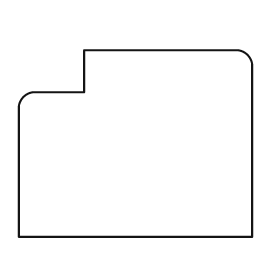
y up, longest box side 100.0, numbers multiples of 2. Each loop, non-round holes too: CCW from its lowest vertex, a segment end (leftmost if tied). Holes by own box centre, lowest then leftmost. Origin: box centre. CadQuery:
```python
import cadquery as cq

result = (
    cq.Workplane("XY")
    .moveTo(-50.0, -40.0)
    .lineTo(50.0, -40.0)
    .lineTo(50.0, 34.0)
    .threePointArc((48.0, 38.0), (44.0, 40.0))
    .lineTo(-22.0, 40.0)
    .lineTo(-22.0, 22.0)
    .lineTo(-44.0, 22.0)
    .threePointArc((-48.0, 20.0), (-50.0, 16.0))
    .close()
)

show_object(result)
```